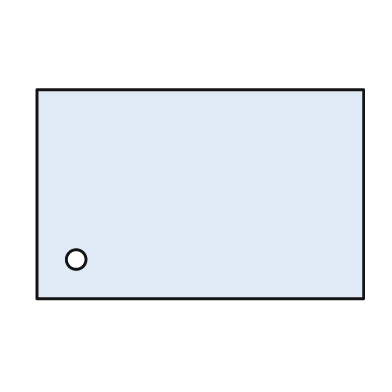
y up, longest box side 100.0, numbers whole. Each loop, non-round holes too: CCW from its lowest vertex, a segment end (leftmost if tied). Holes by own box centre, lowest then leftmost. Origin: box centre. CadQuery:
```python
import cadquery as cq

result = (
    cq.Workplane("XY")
    .moveTo(-50.0, -32.0)
    .lineTo(50.0, -32.0)
    .lineTo(50.0, 32.0)
    .lineTo(-50.0, 32.0)
    .close()
    .moveTo(-38.0, -20.0)
    .circle(3.0)
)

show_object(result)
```